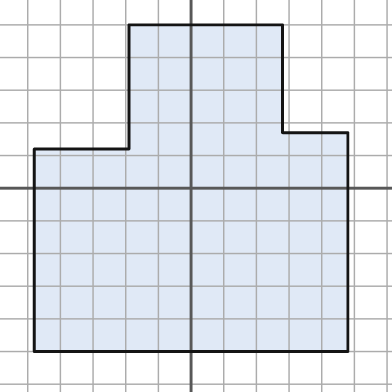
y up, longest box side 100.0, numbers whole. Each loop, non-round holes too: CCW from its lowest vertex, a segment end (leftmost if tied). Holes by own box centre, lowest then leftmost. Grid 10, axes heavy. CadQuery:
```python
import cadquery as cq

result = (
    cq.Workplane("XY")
    .moveTo(-48.0, -50.0)
    .lineTo(48.0, -50.0)
    .lineTo(48.0, 17.0)
    .lineTo(28.0, 17.0)
    .lineTo(28.0, 50.0)
    .lineTo(-19.0, 50.0)
    .lineTo(-19.0, 12.0)
    .lineTo(-48.0, 12.0)
    .close()
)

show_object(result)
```